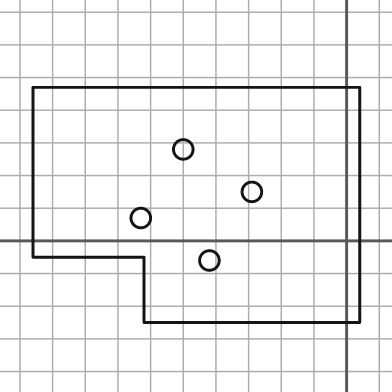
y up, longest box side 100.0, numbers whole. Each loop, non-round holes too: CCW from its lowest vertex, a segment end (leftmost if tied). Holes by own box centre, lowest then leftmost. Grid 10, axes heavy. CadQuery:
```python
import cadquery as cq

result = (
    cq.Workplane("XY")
    .moveTo(-62.0, -25.0)
    .lineTo(4.0, -25.0)
    .lineTo(4.0, 47.0)
    .lineTo(-96.0, 47.0)
    .lineTo(-96.0, -5.0)
    .lineTo(-62.0, -5.0)
    .close()
    .moveTo(-42.0, -6.0)
    .circle(3.0)
    .moveTo(-63.0, 7.0)
    .circle(3.0)
    .moveTo(-29.0, 15.0)
    .circle(3.0)
    .moveTo(-50.0, 28.0)
    .circle(3.0)
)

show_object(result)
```